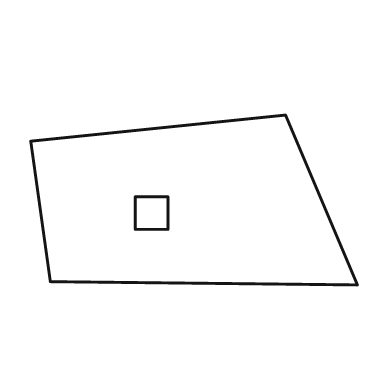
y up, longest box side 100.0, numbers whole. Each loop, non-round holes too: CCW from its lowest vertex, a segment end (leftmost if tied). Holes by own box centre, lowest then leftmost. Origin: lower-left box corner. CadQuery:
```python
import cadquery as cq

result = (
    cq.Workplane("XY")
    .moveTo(100.0, 0.0)
    .lineTo(78.0, 52.0)
    .lineTo(0.0, 44.0)
    .lineTo(6.0, 1.0)
    .close()
    .moveTo(32.0, 17.0)
    .lineTo(42.0, 17.0)
    .lineTo(42.0, 27.0)
    .lineTo(32.0, 27.0)
    .close()
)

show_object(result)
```